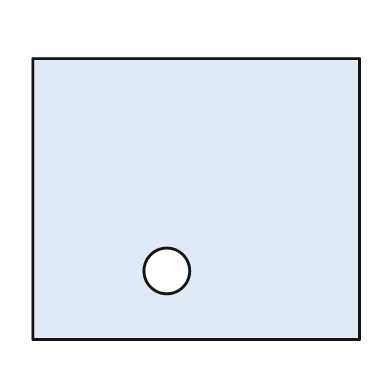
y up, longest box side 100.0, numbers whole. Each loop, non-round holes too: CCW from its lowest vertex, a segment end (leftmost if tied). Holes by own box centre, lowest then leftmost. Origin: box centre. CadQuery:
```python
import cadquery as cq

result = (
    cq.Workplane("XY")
    .moveTo(-50.0, -43.0)
    .lineTo(50.0, -43.0)
    .lineTo(50.0, 43.0)
    .lineTo(-50.0, 43.0)
    .close()
    .moveTo(-9.0, -22.0)
    .circle(7.0)
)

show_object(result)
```